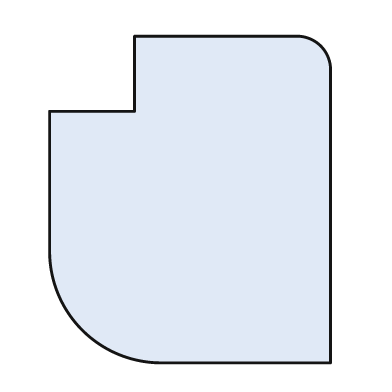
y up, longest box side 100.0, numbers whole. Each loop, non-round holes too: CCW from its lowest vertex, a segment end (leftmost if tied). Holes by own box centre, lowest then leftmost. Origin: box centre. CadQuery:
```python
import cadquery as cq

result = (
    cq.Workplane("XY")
    .moveTo(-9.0, -50.0)
    .lineTo(43.0, -50.0)
    .lineTo(43.0, 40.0)
    .threePointArc((40.0, 47.0), (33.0, 50.0))
    .lineTo(-17.0, 50.0)
    .lineTo(-17.0, 27.0)
    .lineTo(-43.0, 27.0)
    .lineTo(-43.0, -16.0)
    .threePointArc((-33.0, -40.0), (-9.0, -50.0))
    .close()
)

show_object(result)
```